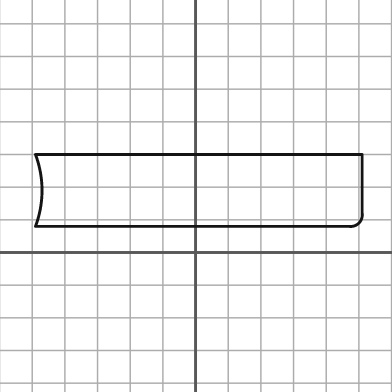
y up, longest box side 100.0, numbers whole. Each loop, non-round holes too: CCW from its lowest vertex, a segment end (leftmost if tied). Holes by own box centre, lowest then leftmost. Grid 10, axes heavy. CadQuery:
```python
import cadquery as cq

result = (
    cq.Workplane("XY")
    .moveTo(-49.0, 8.0)
    .lineTo(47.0, 8.0)
    .threePointArc((50.0, 9.0), (51.0, 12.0))
    .lineTo(51.0, 30.0)
    .lineTo(-49.0, 30.0)
    .threePointArc((-47.0, 19.0), (-49.0, 8.0))
    .close()
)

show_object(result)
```